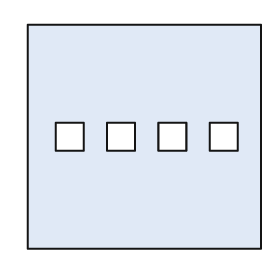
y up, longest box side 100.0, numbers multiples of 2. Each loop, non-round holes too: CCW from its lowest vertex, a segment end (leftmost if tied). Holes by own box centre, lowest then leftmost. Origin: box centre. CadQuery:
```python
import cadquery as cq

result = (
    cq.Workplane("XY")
    .moveTo(-50.0, -48.0)
    .lineTo(50.0, -48.0)
    .lineTo(50.0, 48.0)
    .lineTo(-50.0, 48.0)
    .close()
    .moveTo(-38.0, -6.0)
    .lineTo(-26.0, -6.0)
    .lineTo(-26.0, 6.0)
    .lineTo(-38.0, 6.0)
    .close()
    .moveTo(-16.0, -6.0)
    .lineTo(-4.0, -6.0)
    .lineTo(-4.0, 6.0)
    .lineTo(-16.0, 6.0)
    .close()
    .moveTo(6.0, -6.0)
    .lineTo(18.0, -6.0)
    .lineTo(18.0, 6.0)
    .lineTo(6.0, 6.0)
    .close()
    .moveTo(28.0, -6.0)
    .lineTo(40.0, -6.0)
    .lineTo(40.0, 6.0)
    .lineTo(28.0, 6.0)
    .close()
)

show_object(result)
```